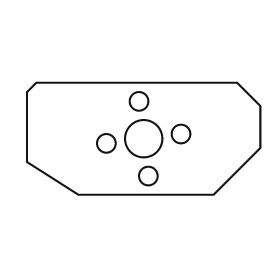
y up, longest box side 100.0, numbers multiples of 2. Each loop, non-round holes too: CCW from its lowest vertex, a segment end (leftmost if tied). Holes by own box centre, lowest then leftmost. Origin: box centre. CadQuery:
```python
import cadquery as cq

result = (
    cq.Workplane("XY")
    .moveTo(-28.0, -24.0)
    .lineTo(30.0, -24.0)
    .lineTo(50.0, -4.0)
    .lineTo(50.0, 14.0)
    .lineTo(40.0, 24.0)
    .lineTo(-46.0, 24.0)
    .lineTo(-50.0, 20.0)
    .lineTo(-50.0, -10.0)
    .close()
    .moveTo(2.0, -16.0)
    .circle(4.0)
    .moveTo(-16.0, -2.0)
    .circle(4.0)
    .moveTo(0.0, 0.0)
    .circle(8.0)
    .moveTo(16.0, 2.0)
    .circle(4.0)
    .moveTo(-2.0, 16.0)
    .circle(4.0)
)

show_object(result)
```